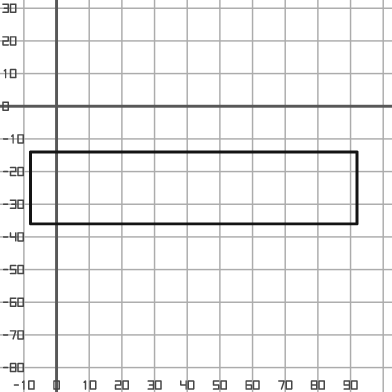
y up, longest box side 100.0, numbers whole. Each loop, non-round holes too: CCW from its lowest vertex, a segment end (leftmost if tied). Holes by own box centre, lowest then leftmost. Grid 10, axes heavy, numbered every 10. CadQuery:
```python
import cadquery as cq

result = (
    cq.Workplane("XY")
    .moveTo(-8.0, -36.0)
    .lineTo(92.0, -36.0)
    .lineTo(92.0, -14.0)
    .lineTo(-8.0, -14.0)
    .close()
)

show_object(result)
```